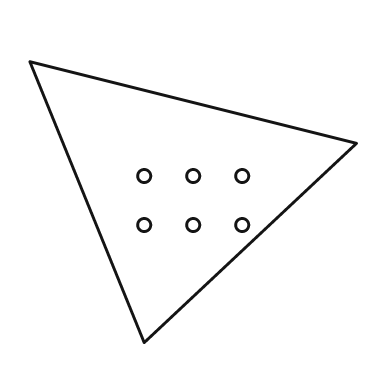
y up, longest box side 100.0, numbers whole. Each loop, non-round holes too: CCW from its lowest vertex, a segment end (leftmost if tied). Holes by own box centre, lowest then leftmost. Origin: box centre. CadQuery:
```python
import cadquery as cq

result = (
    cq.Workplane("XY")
    .moveTo(-15.0, -43.0)
    .lineTo(50.0, 18.0)
    .lineTo(-50.0, 43.0)
    .close()
    .moveTo(-15.0, -7.0)
    .circle(2.0)
    .moveTo(0.0, -7.0)
    .circle(2.0)
    .moveTo(15.0, -7.0)
    .circle(2.0)
    .moveTo(-15.0, 8.0)
    .circle(2.0)
    .moveTo(0.0, 8.0)
    .circle(2.0)
    .moveTo(15.0, 8.0)
    .circle(2.0)
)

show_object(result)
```